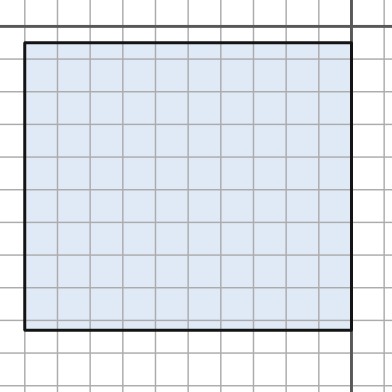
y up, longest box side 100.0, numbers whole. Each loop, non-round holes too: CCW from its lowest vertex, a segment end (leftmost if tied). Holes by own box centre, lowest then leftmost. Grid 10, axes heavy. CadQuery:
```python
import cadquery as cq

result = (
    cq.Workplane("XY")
    .moveTo(-100.0, -93.0)
    .lineTo(0.0, -93.0)
    .lineTo(0.0, -5.0)
    .lineTo(-100.0, -5.0)
    .close()
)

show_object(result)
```